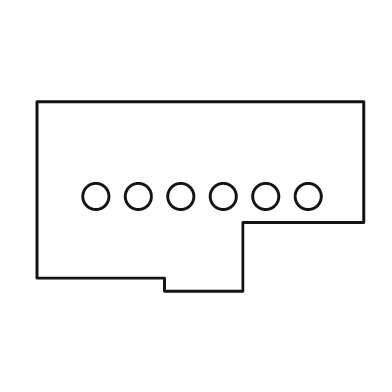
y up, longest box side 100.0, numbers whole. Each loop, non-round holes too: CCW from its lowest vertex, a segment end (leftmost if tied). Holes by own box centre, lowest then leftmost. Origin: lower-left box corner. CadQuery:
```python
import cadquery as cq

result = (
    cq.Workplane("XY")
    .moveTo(39.0, 0.0)
    .lineTo(63.0, 0.0)
    .lineTo(63.0, 21.0)
    .lineTo(100.0, 21.0)
    .lineTo(100.0, 58.0)
    .lineTo(0.0, 58.0)
    .lineTo(0.0, 4.0)
    .lineTo(39.0, 4.0)
    .close()
    .moveTo(18.0, 29.0)
    .circle(4.0)
    .moveTo(31.0, 29.0)
    .circle(4.0)
    .moveTo(44.0, 29.0)
    .circle(4.0)
    .moveTo(57.0, 29.0)
    .circle(4.0)
    .moveTo(70.0, 29.0)
    .circle(4.0)
    .moveTo(83.0, 29.0)
    .circle(4.0)
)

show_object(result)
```